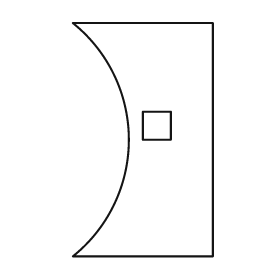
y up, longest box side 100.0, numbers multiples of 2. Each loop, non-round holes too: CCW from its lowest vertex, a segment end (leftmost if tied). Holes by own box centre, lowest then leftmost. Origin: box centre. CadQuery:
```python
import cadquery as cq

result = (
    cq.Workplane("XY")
    .moveTo(-30.0, -50.0)
    .lineTo(30.0, -50.0)
    .lineTo(30.0, 50.0)
    .lineTo(-30.0, 50.0)
    .threePointArc((-6.0, 0.0), (-30.0, -50.0))
    .close()
    .moveTo(0.0, 0.0)
    .lineTo(12.0, 0.0)
    .lineTo(12.0, 12.0)
    .lineTo(0.0, 12.0)
    .close()
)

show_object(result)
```